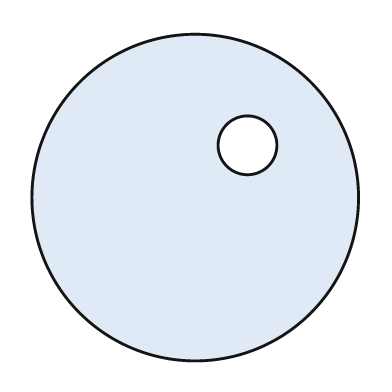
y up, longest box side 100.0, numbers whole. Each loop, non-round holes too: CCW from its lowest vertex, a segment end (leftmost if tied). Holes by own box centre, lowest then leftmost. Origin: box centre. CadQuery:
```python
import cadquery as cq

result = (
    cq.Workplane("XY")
    .moveTo(0.0, 0.0)
    .circle(50.0)
    .moveTo(16.0, 16.0)
    .circle(9.0)
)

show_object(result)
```